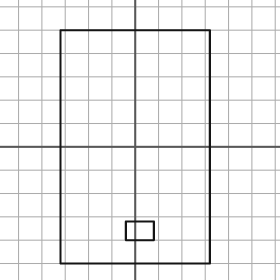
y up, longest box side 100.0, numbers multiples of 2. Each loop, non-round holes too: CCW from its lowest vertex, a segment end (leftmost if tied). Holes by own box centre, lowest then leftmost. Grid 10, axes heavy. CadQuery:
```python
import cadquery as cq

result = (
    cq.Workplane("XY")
    .moveTo(-32.0, -50.0)
    .lineTo(32.0, -50.0)
    .lineTo(32.0, 50.0)
    .lineTo(-32.0, 50.0)
    .close()
    .moveTo(-4.0, -40.0)
    .lineTo(8.0, -40.0)
    .lineTo(8.0, -32.0)
    .lineTo(-4.0, -32.0)
    .close()
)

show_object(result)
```